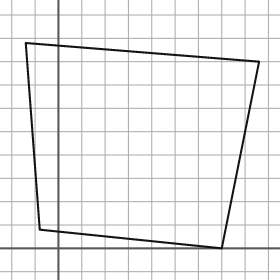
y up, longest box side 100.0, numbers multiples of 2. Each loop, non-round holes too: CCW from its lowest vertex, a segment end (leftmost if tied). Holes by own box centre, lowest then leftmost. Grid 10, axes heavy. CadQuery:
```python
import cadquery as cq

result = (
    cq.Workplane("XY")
    .moveTo(70.0, 0.0)
    .lineTo(86.0, 80.0)
    .lineTo(-14.0, 88.0)
    .lineTo(-8.0, 8.0)
    .close()
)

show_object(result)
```